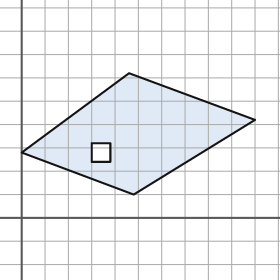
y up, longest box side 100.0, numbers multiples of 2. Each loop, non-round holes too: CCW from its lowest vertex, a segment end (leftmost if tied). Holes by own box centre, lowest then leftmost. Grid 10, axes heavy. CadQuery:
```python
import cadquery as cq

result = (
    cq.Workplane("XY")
    .moveTo(48.0, 10.0)
    .lineTo(100.0, 42.0)
    .lineTo(46.0, 62.0)
    .lineTo(0.0, 28.0)
    .close()
    .moveTo(30.0, 24.0)
    .lineTo(38.0, 24.0)
    .lineTo(38.0, 32.0)
    .lineTo(30.0, 32.0)
    .close()
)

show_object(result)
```